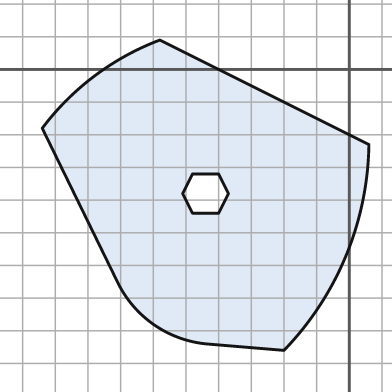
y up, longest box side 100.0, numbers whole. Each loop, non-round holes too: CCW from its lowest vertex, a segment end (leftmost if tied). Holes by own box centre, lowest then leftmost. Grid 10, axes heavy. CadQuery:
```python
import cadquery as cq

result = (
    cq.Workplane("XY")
    .moveTo(-20.0, -86.0)
    .threePointArc((-1.0, -57.0), (6.0, -23.0))
    .lineTo(-58.0, 9.0)
    .threePointArc((-78.0, -2.0), (-94.0, -18.0))
    .lineTo(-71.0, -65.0)
    .threePointArc((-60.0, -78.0), (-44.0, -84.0))
    .close()
    .moveTo(-48.0, -44.0)
    .lineTo(-40.0, -44.0)
    .lineTo(-37.0, -38.0)
    .lineTo(-40.0, -32.0)
    .lineTo(-48.0, -32.0)
    .lineTo(-51.0, -38.0)
    .close()
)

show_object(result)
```